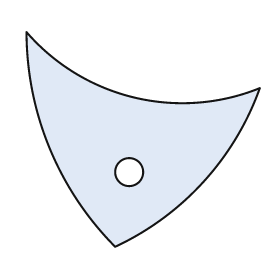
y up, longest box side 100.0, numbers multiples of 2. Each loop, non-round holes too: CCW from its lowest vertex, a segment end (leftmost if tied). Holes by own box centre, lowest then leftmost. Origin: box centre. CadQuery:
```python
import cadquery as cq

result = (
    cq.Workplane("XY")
    .moveTo(-12.0, -46.0)
    .threePointArc((26.0, -18.0), (50.0, 22.0))
    .threePointArc((-4.0, 18.0), (-50.0, 46.0))
    .threePointArc((-40.0, -4.0), (-12.0, -46.0))
    .close()
    .moveTo(-6.0, -14.0)
    .circle(6.0)
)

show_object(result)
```